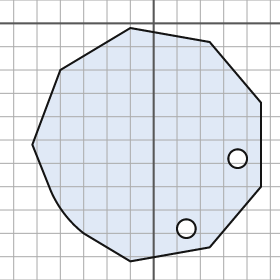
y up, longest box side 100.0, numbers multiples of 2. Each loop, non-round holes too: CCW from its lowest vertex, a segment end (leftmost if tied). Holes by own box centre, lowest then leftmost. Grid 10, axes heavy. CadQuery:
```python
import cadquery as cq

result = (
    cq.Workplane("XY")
    .moveTo(-10.0, -102.0)
    .lineTo(24.0, -96.0)
    .lineTo(46.0, -70.0)
    .lineTo(46.0, -34.0)
    .lineTo(24.0, -8.0)
    .lineTo(-10.0, -2.0)
    .lineTo(-40.0, -20.0)
    .lineTo(-52.0, -52.0)
    .lineTo(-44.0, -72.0)
    .threePointArc((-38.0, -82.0), (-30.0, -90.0))
    .close()
    .moveTo(14.0, -88.0)
    .circle(4.0)
    .moveTo(36.0, -58.0)
    .circle(4.0)
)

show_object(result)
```